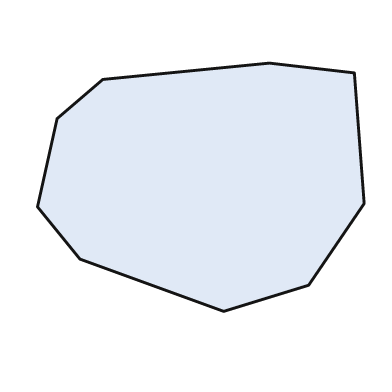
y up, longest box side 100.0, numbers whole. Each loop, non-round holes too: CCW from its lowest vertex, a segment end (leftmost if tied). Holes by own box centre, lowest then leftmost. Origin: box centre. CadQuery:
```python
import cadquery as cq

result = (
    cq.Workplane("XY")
    .moveTo(7.0, -38.0)
    .lineTo(33.0, -30.0)
    .lineTo(50.0, -5.0)
    .lineTo(47.0, 35.0)
    .lineTo(21.0, 38.0)
    .lineTo(-30.0, 33.0)
    .lineTo(-44.0, 21.0)
    .lineTo(-50.0, -6.0)
    .lineTo(-37.0, -22.0)
    .close()
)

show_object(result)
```